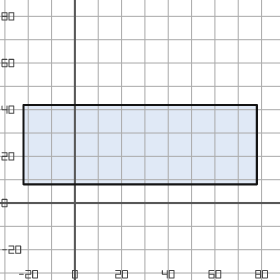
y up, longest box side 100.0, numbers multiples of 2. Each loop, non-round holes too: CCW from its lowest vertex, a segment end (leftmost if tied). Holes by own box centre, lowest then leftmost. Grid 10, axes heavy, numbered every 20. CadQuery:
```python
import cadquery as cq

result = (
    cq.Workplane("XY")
    .moveTo(-22.0, 8.0)
    .lineTo(78.0, 8.0)
    .lineTo(78.0, 42.0)
    .lineTo(-22.0, 42.0)
    .close()
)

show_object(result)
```